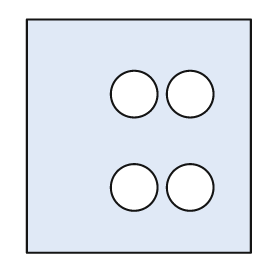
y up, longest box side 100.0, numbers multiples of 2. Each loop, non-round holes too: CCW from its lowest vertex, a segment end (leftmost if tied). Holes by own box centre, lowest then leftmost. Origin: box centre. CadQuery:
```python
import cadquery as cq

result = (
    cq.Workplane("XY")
    .moveTo(-48.0, -50.0)
    .lineTo(48.0, -50.0)
    .lineTo(48.0, 50.0)
    .lineTo(-48.0, 50.0)
    .close()
    .moveTo(-2.0, -22.0)
    .circle(10.0)
    .moveTo(22.0, -22.0)
    .circle(10.0)
    .moveTo(-2.0, 18.0)
    .circle(10.0)
    .moveTo(22.0, 18.0)
    .circle(10.0)
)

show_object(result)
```